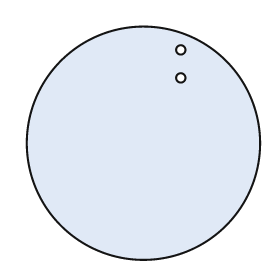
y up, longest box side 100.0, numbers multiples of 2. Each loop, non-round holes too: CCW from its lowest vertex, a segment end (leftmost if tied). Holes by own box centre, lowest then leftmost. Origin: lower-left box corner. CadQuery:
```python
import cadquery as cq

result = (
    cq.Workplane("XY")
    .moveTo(50.0, 50.0)
    .circle(50.0)
    .moveTo(66.0, 78.0)
    .circle(2.0)
    .moveTo(66.0, 90.0)
    .circle(2.0)
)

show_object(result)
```